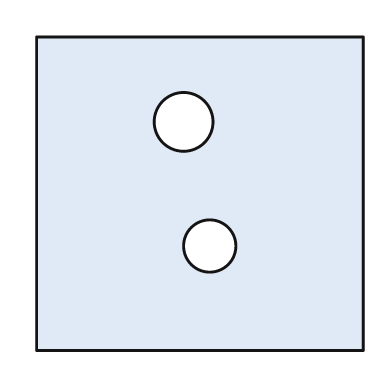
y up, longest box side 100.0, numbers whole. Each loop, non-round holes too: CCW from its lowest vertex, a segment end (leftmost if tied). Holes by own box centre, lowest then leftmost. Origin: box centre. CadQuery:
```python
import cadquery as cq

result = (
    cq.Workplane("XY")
    .moveTo(-50.0, -48.0)
    .lineTo(50.0, -48.0)
    .lineTo(50.0, 48.0)
    .lineTo(-50.0, 48.0)
    .close()
    .moveTo(3.0, -16.0)
    .circle(8.0)
    .moveTo(-5.0, 22.0)
    .circle(9.0)
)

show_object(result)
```